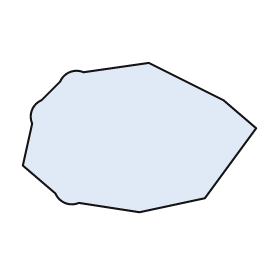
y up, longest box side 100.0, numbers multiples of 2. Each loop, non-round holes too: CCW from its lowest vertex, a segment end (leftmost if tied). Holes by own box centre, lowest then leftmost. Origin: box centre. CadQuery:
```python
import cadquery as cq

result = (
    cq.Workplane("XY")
    .moveTo(0.0, -32.0)
    .lineTo(28.0, -26.0)
    .lineTo(50.0, 4.0)
    .lineTo(36.0, 16.0)
    .lineTo(4.0, 32.0)
    .lineTo(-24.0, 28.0)
    .threePointArc((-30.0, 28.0), (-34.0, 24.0))
    .lineTo(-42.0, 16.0)
    .threePointArc((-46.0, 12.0), (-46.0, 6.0))
    .lineTo(-50.0, -12.0)
    .lineTo(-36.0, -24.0)
    .threePointArc((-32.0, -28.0), (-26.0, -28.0))
    .close()
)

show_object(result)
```